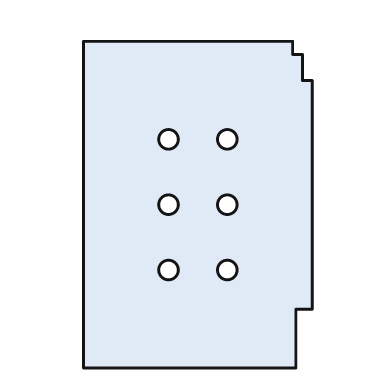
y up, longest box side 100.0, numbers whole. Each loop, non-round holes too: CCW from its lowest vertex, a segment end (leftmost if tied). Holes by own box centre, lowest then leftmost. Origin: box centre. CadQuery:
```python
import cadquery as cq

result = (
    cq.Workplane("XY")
    .moveTo(-35.0, -50.0)
    .lineTo(30.0, -50.0)
    .lineTo(30.0, -32.0)
    .lineTo(35.0, -32.0)
    .lineTo(35.0, 38.0)
    .lineTo(32.0, 38.0)
    .lineTo(32.0, 46.0)
    .lineTo(29.0, 46.0)
    .lineTo(29.0, 50.0)
    .lineTo(-35.0, 50.0)
    .close()
    .moveTo(-9.0, -20.0)
    .circle(3.0)
    .moveTo(9.0, -20.0)
    .circle(3.0)
    .moveTo(-9.0, 0.0)
    .circle(3.0)
    .moveTo(9.0, 0.0)
    .circle(3.0)
    .moveTo(-9.0, 20.0)
    .circle(3.0)
    .moveTo(9.0, 20.0)
    .circle(3.0)
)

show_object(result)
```